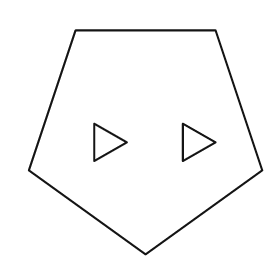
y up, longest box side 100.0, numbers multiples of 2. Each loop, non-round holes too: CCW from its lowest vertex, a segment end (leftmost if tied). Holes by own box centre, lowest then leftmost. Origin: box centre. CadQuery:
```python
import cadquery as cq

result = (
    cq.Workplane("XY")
    .moveTo(0.0, -48.0)
    .lineTo(50.0, -12.0)
    .lineTo(30.0, 48.0)
    .lineTo(-30.0, 48.0)
    .lineTo(-50.0, -12.0)
    .close()
    .moveTo(-22.0, -8.0)
    .lineTo(-8.0, 0.0)
    .lineTo(-22.0, 8.0)
    .close()
    .moveTo(16.0, -8.0)
    .lineTo(30.0, 0.0)
    .lineTo(16.0, 8.0)
    .close()
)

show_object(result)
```